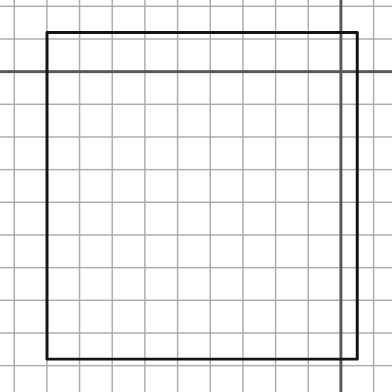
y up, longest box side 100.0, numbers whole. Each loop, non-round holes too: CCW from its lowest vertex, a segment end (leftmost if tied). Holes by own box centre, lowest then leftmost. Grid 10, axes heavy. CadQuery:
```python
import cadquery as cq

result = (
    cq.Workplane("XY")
    .moveTo(-90.0, -88.0)
    .lineTo(5.0, -88.0)
    .lineTo(5.0, 12.0)
    .lineTo(-90.0, 12.0)
    .close()
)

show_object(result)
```